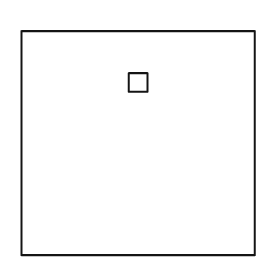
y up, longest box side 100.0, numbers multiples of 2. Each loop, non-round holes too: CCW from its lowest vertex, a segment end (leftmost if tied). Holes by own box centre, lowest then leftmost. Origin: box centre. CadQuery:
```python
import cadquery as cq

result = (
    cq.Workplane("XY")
    .moveTo(-50.0, -48.0)
    .lineTo(50.0, -48.0)
    .lineTo(50.0, 48.0)
    .lineTo(-50.0, 48.0)
    .close()
    .moveTo(-4.0, 22.0)
    .lineTo(4.0, 22.0)
    .lineTo(4.0, 30.0)
    .lineTo(-4.0, 30.0)
    .close()
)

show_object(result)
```